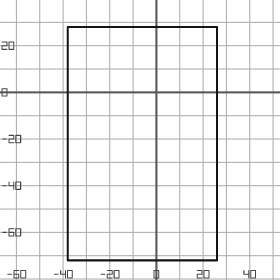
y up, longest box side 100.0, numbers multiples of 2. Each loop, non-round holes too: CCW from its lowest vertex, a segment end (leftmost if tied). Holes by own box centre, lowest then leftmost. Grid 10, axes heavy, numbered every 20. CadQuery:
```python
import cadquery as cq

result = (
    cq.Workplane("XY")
    .moveTo(-38.0, -72.0)
    .lineTo(26.0, -72.0)
    .lineTo(26.0, 28.0)
    .lineTo(-38.0, 28.0)
    .close()
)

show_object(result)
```